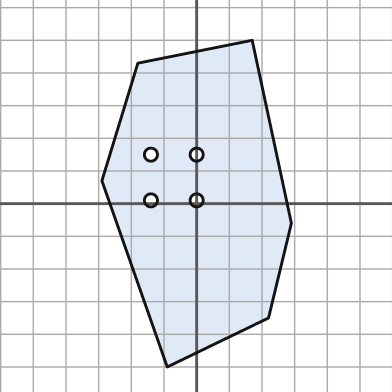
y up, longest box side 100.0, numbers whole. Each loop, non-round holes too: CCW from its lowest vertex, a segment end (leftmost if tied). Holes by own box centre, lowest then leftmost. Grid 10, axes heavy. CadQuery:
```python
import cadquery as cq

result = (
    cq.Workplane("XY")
    .moveTo(-9.0, -50.0)
    .lineTo(22.0, -35.0)
    .lineTo(29.0, -6.0)
    .lineTo(17.0, 50.0)
    .lineTo(-18.0, 43.0)
    .lineTo(-29.0, 7.0)
    .close()
    .moveTo(-14.0, 1.0)
    .circle(2.0)
    .moveTo(0.0, 1.0)
    .circle(2.0)
    .moveTo(-14.0, 15.0)
    .circle(2.0)
    .moveTo(0.0, 15.0)
    .circle(2.0)
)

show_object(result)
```